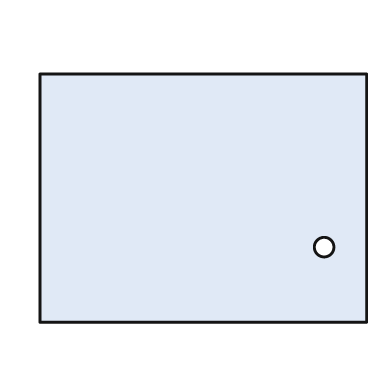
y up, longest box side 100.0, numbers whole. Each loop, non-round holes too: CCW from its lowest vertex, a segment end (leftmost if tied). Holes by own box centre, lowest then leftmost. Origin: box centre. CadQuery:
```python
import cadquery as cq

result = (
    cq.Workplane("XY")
    .moveTo(-50.0, -38.0)
    .lineTo(50.0, -38.0)
    .lineTo(50.0, 38.0)
    .lineTo(-50.0, 38.0)
    .close()
    .moveTo(37.0, -15.0)
    .circle(3.0)
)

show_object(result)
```